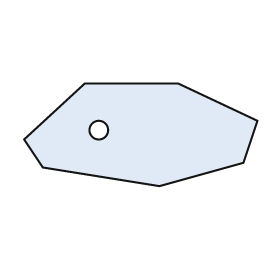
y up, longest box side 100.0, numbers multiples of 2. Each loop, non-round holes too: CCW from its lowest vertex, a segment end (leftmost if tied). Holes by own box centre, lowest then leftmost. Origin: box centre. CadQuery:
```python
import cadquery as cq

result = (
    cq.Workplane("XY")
    .moveTo(8.0, -22.0)
    .lineTo(44.0, -12.0)
    .lineTo(50.0, 6.0)
    .lineTo(16.0, 22.0)
    .lineTo(-24.0, 22.0)
    .lineTo(-50.0, -2.0)
    .lineTo(-42.0, -14.0)
    .close()
    .moveTo(-18.0, 2.0)
    .circle(4.0)
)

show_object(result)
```